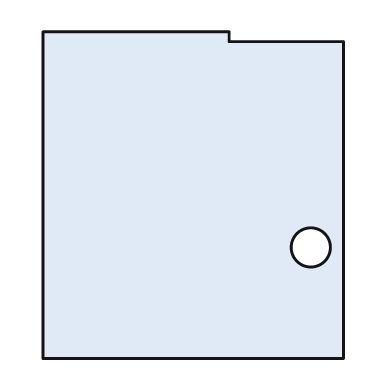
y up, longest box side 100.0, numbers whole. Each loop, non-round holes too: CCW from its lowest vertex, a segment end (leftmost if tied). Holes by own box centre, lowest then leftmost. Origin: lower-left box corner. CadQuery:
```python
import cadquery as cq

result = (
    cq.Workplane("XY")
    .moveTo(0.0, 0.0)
    .lineTo(92.0, 0.0)
    .lineTo(92.0, 97.0)
    .lineTo(57.0, 97.0)
    .lineTo(57.0, 100.0)
    .lineTo(0.0, 100.0)
    .close()
    .moveTo(82.0, 34.0)
    .circle(6.0)
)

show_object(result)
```